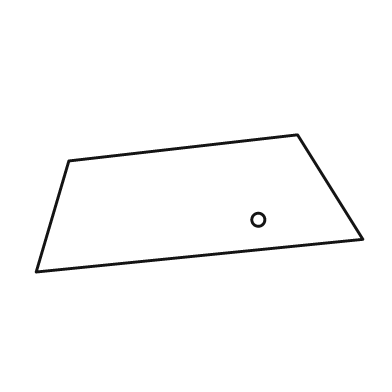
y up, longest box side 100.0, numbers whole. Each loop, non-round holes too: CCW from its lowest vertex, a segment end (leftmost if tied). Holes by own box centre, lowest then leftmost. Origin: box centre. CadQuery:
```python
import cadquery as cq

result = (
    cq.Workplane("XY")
    .moveTo(-50.0, -21.0)
    .lineTo(50.0, -11.0)
    .lineTo(30.0, 21.0)
    .lineTo(-40.0, 13.0)
    .close()
    .moveTo(18.0, -5.0)
    .circle(2.0)
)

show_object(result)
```